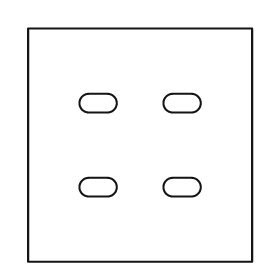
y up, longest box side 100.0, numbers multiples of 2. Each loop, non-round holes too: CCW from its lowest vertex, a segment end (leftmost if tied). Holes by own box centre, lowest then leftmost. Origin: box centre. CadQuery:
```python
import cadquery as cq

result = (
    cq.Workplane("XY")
    .moveTo(-48.0, -50.0)
    .lineTo(48.0, -50.0)
    .lineTo(48.0, 50.0)
    .lineTo(-48.0, 50.0)
    .close()
    .moveTo(-22.0, -22.0)
    .lineTo(-14.0, -22.0)
    .threePointArc((-10.0, -18.0), (-14.0, -14.0))
    .lineTo(-22.0, -14.0)
    .threePointArc((-26.0, -18.0), (-22.0, -22.0))
    .close()
    .moveTo(14.0, -22.0)
    .lineTo(22.0, -22.0)
    .threePointArc((26.0, -18.0), (22.0, -14.0))
    .lineTo(14.0, -14.0)
    .threePointArc((10.0, -18.0), (14.0, -22.0))
    .close()
    .moveTo(-22.0, 14.0)
    .lineTo(-14.0, 14.0)
    .threePointArc((-10.0, 18.0), (-14.0, 22.0))
    .lineTo(-22.0, 22.0)
    .threePointArc((-26.0, 18.0), (-22.0, 14.0))
    .close()
    .moveTo(14.0, 14.0)
    .lineTo(22.0, 14.0)
    .threePointArc((26.0, 18.0), (22.0, 22.0))
    .lineTo(14.0, 22.0)
    .threePointArc((10.0, 18.0), (14.0, 14.0))
    .close()
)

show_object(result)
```